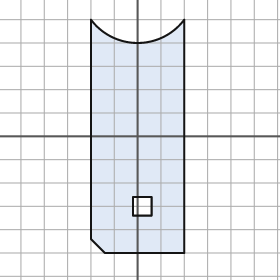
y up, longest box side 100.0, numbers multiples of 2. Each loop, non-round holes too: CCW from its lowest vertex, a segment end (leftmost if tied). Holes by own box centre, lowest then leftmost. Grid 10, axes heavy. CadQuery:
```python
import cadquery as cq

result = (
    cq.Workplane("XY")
    .moveTo(-14.0, -50.0)
    .lineTo(20.0, -50.0)
    .lineTo(20.0, 50.0)
    .threePointArc((0.0, 40.0), (-20.0, 50.0))
    .lineTo(-20.0, -44.0)
    .close()
    .moveTo(-2.0, -34.0)
    .lineTo(6.0, -34.0)
    .lineTo(6.0, -26.0)
    .lineTo(-2.0, -26.0)
    .close()
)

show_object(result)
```